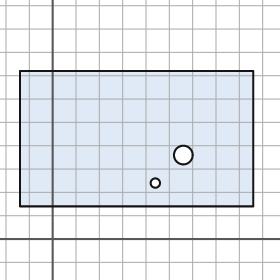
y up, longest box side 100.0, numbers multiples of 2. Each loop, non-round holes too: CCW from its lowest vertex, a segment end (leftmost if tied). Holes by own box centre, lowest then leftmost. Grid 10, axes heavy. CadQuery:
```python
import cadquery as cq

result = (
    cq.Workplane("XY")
    .moveTo(-14.0, 14.0)
    .lineTo(86.0, 14.0)
    .lineTo(86.0, 72.0)
    .lineTo(-14.0, 72.0)
    .close()
    .moveTo(44.0, 24.0)
    .circle(2.0)
    .moveTo(56.0, 36.0)
    .circle(4.0)
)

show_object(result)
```